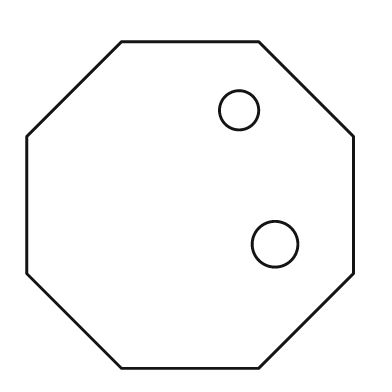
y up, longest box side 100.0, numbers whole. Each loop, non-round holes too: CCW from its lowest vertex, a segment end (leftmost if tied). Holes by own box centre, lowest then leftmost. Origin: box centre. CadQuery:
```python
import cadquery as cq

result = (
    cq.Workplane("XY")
    .moveTo(-21.0, -50.0)
    .lineTo(21.0, -50.0)
    .lineTo(50.0, -21.0)
    .lineTo(50.0, 21.0)
    .lineTo(21.0, 50.0)
    .lineTo(-21.0, 50.0)
    .lineTo(-50.0, 21.0)
    .lineTo(-50.0, -21.0)
    .close()
    .moveTo(26.0, -12.0)
    .circle(7.0)
    .moveTo(15.0, 29.0)
    .circle(6.0)
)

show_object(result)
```